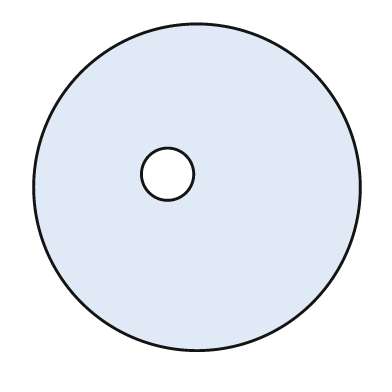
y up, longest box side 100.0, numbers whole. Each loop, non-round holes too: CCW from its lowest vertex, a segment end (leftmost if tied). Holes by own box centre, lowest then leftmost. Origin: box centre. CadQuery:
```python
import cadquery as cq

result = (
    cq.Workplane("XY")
    .moveTo(0.0, 0.0)
    .circle(50.0)
    .moveTo(-9.0, 4.0)
    .circle(8.0)
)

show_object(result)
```